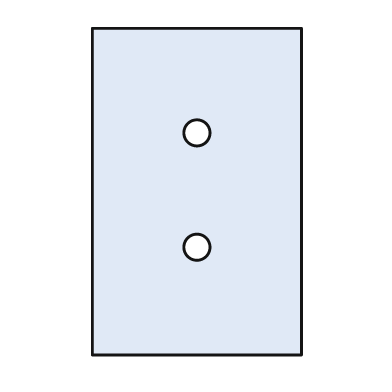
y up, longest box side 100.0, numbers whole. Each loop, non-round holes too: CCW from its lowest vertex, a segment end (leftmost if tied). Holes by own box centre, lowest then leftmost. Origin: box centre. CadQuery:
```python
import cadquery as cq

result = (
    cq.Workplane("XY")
    .moveTo(-32.0, -50.0)
    .lineTo(32.0, -50.0)
    .lineTo(32.0, 50.0)
    .lineTo(-32.0, 50.0)
    .close()
    .moveTo(0.0, -17.0)
    .circle(4.0)
    .moveTo(0.0, 18.0)
    .circle(4.0)
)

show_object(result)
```